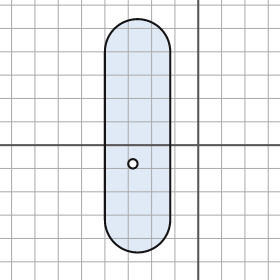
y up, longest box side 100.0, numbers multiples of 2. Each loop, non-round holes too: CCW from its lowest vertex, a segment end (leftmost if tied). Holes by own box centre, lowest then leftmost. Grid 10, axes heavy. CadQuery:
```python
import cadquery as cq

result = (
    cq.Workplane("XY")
    .moveTo(-40.0, -32.0)
    .threePointArc((-26.0, -46.0), (-12.0, -32.0))
    .lineTo(-12.0, 40.0)
    .threePointArc((-26.0, 54.0), (-40.0, 40.0))
    .close()
    .moveTo(-28.0, -8.0)
    .circle(2.0)
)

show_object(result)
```